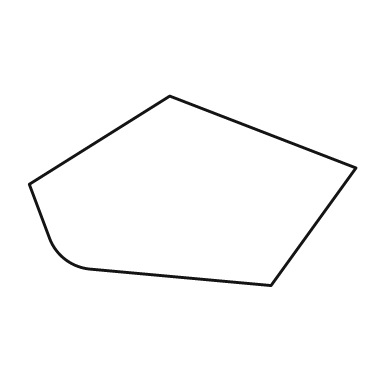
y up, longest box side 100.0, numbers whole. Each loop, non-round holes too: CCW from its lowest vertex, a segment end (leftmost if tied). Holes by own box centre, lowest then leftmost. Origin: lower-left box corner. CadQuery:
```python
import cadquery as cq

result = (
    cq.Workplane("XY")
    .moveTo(74.0, 0.0)
    .lineTo(100.0, 36.0)
    .lineTo(43.0, 58.0)
    .lineTo(0.0, 31.0)
    .lineTo(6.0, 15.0)
    .threePointArc((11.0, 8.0), (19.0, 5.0))
    .close()
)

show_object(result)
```